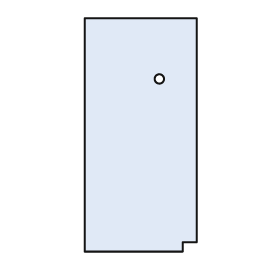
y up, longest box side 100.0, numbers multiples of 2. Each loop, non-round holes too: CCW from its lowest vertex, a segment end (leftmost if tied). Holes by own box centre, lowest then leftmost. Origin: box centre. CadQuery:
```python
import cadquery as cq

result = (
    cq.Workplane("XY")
    .moveTo(-24.0, -50.0)
    .lineTo(18.0, -50.0)
    .lineTo(18.0, -46.0)
    .lineTo(24.0, -46.0)
    .lineTo(24.0, 50.0)
    .lineTo(-24.0, 50.0)
    .close()
    .moveTo(8.0, 24.0)
    .circle(2.0)
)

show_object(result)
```